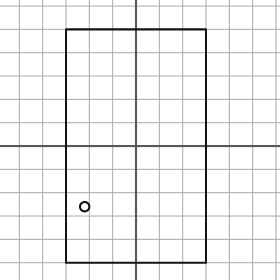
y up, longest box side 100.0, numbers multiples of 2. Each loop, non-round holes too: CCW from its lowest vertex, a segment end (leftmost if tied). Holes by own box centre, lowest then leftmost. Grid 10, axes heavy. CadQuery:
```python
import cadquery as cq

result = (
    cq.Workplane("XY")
    .moveTo(-30.0, -50.0)
    .lineTo(30.0, -50.0)
    .lineTo(30.0, 50.0)
    .lineTo(-30.0, 50.0)
    .close()
    .moveTo(-22.0, -26.0)
    .circle(2.0)
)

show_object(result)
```